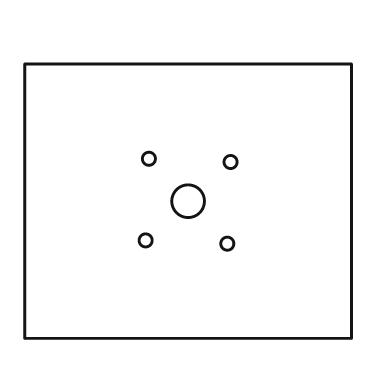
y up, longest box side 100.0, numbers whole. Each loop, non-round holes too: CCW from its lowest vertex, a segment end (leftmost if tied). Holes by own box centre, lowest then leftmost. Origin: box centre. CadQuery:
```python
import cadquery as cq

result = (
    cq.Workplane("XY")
    .moveTo(-50.0, -42.0)
    .lineTo(50.0, -42.0)
    .lineTo(50.0, 42.0)
    .lineTo(-50.0, 42.0)
    .close()
    .moveTo(12.0, -13.0)
    .circle(2.0)
    .moveTo(-13.0, -12.0)
    .circle(2.0)
    .moveTo(0.0, 0.0)
    .circle(5.0)
    .moveTo(13.0, 12.0)
    .circle(2.0)
    .moveTo(-12.0, 13.0)
    .circle(2.0)
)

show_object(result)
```